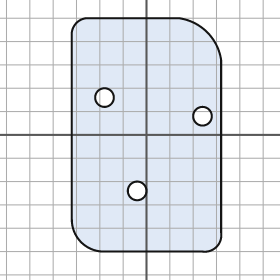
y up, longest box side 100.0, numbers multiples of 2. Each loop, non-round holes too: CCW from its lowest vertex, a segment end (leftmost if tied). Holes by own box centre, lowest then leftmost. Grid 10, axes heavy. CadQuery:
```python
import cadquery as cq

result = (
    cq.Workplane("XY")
    .moveTo(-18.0, -50.0)
    .lineTo(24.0, -50.0)
    .threePointArc((30.0, -48.0), (32.0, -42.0))
    .lineTo(32.0, 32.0)
    .threePointArc((26.0, 44.0), (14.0, 50.0))
    .lineTo(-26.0, 50.0)
    .threePointArc((-30.0, 48.0), (-32.0, 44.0))
    .lineTo(-32.0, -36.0)
    .threePointArc((-28.0, -46.0), (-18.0, -50.0))
    .close()
    .moveTo(-4.0, -24.0)
    .circle(4.0)
    .moveTo(24.0, 8.0)
    .circle(4.0)
    .moveTo(-18.0, 16.0)
    .circle(4.0)
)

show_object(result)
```